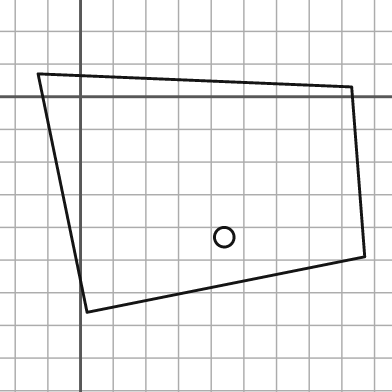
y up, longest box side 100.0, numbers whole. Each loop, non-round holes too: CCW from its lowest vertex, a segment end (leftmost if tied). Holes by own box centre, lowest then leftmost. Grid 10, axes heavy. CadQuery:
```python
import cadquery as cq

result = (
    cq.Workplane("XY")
    .moveTo(2.0, -66.0)
    .lineTo(87.0, -49.0)
    .lineTo(83.0, 3.0)
    .lineTo(-13.0, 7.0)
    .close()
    .moveTo(44.0, -43.0)
    .circle(3.0)
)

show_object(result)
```